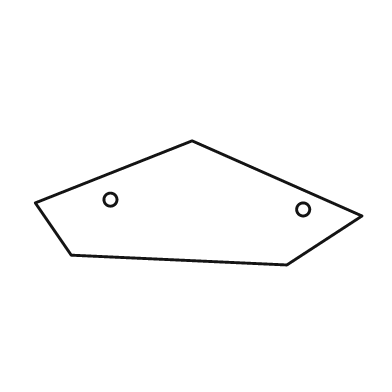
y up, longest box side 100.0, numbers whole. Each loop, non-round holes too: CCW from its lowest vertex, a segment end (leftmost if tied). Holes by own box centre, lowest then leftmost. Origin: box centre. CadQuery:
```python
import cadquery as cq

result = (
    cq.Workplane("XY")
    .moveTo(27.0, -19.0)
    .lineTo(50.0, -4.0)
    .lineTo(-2.0, 19.0)
    .lineTo(-50.0, 0.0)
    .lineTo(-39.0, -16.0)
    .close()
    .moveTo(32.0, -2.0)
    .circle(2.0)
    .moveTo(-27.0, 1.0)
    .circle(2.0)
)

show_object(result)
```